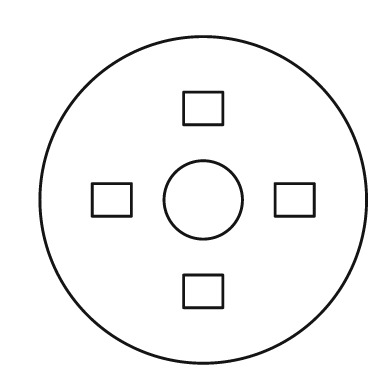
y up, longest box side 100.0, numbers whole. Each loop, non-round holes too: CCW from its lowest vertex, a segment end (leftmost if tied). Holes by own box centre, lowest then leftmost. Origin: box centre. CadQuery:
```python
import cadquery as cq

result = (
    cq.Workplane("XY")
    .moveTo(0.0, 0.0)
    .circle(50.0)
    .moveTo(-6.0, -33.0)
    .lineTo(6.0, -33.0)
    .lineTo(6.0, -23.0)
    .lineTo(-6.0, -23.0)
    .close()
    .moveTo(-34.0, -5.0)
    .lineTo(-22.0, -5.0)
    .lineTo(-22.0, 5.0)
    .lineTo(-34.0, 5.0)
    .close()
    .moveTo(0.0, 0.0)
    .circle(12.0)
    .moveTo(22.0, -5.0)
    .lineTo(34.0, -5.0)
    .lineTo(34.0, 5.0)
    .lineTo(22.0, 5.0)
    .close()
    .moveTo(-6.0, 23.0)
    .lineTo(6.0, 23.0)
    .lineTo(6.0, 33.0)
    .lineTo(-6.0, 33.0)
    .close()
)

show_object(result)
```